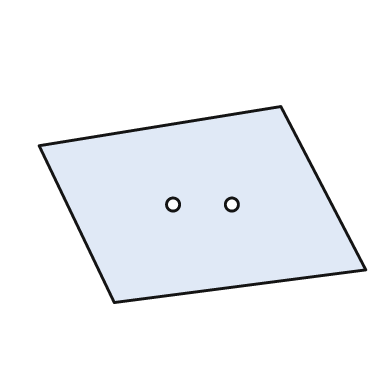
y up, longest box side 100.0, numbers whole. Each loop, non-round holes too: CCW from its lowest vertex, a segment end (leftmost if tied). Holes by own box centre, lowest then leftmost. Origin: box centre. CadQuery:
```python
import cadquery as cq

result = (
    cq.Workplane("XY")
    .moveTo(-27.0, -30.0)
    .lineTo(50.0, -20.0)
    .lineTo(24.0, 30.0)
    .lineTo(-50.0, 18.0)
    .close()
    .moveTo(-9.0, 0.0)
    .circle(2.0)
    .moveTo(9.0, 0.0)
    .circle(2.0)
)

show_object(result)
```